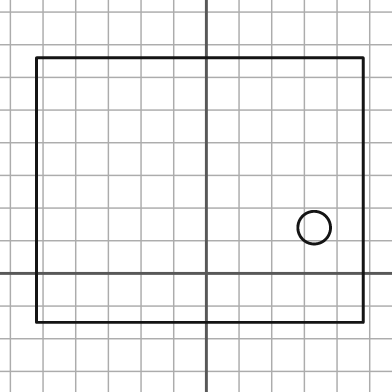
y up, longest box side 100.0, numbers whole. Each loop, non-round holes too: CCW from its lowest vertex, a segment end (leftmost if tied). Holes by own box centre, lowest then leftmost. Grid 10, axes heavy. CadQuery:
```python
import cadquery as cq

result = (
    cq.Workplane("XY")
    .moveTo(-52.0, -15.0)
    .lineTo(48.0, -15.0)
    .lineTo(48.0, 66.0)
    .lineTo(-52.0, 66.0)
    .close()
    .moveTo(33.0, 14.0)
    .circle(5.0)
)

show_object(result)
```